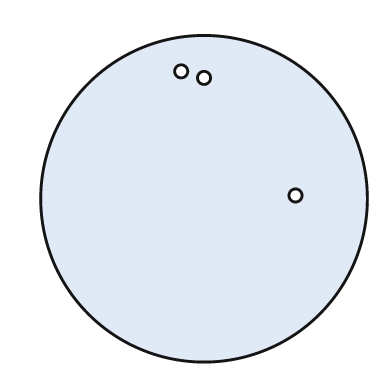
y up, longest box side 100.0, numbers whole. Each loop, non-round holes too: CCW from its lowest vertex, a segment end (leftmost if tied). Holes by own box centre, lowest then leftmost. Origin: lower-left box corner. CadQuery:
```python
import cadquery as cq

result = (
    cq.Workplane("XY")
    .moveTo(50.0, 50.0)
    .circle(50.0)
    .moveTo(78.0, 51.0)
    .circle(2.0)
    .moveTo(50.0, 87.0)
    .circle(2.0)
    .moveTo(43.0, 89.0)
    .circle(2.0)
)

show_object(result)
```